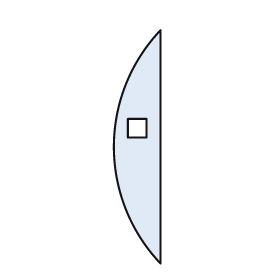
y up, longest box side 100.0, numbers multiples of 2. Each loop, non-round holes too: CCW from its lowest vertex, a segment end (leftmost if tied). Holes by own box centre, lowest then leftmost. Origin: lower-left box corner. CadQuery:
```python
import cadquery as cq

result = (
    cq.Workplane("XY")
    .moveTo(20.0, 0.0)
    .lineTo(20.0, 100.0)
    .threePointArc((0.0, 50.0), (20.0, 0.0))
    .close()
    .moveTo(6.0, 54.0)
    .lineTo(14.0, 54.0)
    .lineTo(14.0, 62.0)
    .lineTo(6.0, 62.0)
    .close()
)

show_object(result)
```